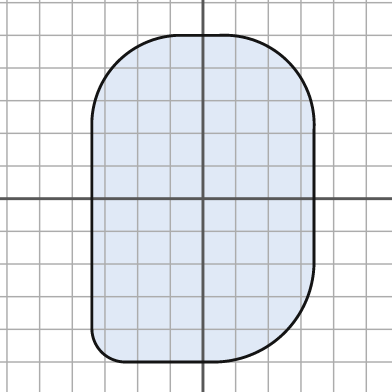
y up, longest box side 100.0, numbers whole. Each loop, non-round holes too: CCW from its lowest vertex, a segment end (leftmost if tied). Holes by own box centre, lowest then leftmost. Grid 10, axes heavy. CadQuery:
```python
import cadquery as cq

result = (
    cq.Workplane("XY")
    .moveTo(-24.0, -50.0)
    .lineTo(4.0, -50.0)
    .threePointArc((25.0, -41.0), (34.0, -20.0))
    .lineTo(34.0, 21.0)
    .threePointArc((26.0, 42.0), (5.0, 50.0))
    .lineTo(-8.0, 50.0)
    .threePointArc((-26.0, 42.0), (-34.0, 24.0))
    .lineTo(-34.0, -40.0)
    .threePointArc((-31.0, -47.0), (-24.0, -50.0))
    .close()
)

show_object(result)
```